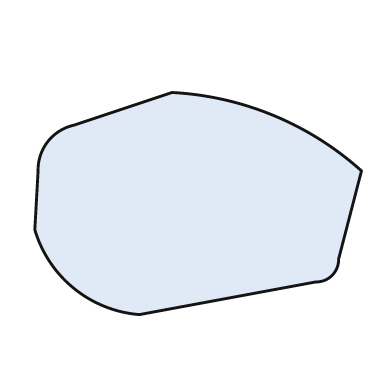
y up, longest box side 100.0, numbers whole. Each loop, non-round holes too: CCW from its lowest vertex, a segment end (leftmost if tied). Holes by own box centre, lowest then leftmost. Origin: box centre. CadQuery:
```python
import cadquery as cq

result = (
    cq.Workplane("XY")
    .moveTo(-18.0, -34.0)
    .lineTo(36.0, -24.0)
    .threePointArc((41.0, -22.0), (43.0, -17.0))
    .lineTo(50.0, 10.0)
    .threePointArc((23.0, 27.0), (-8.0, 34.0))
    .lineTo(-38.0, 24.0)
    .threePointArc((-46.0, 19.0), (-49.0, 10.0))
    .lineTo(-50.0, -8.0)
    .threePointArc((-38.0, -26.0), (-18.0, -34.0))
    .close()
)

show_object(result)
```